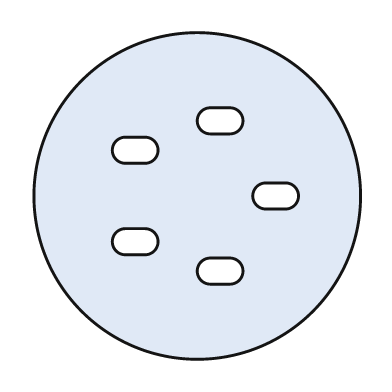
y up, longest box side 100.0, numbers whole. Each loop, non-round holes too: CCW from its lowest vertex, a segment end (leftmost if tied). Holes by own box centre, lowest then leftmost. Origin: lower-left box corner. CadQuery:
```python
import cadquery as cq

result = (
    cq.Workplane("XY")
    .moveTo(50.0, 50.0)
    .circle(50.0)
    .moveTo(54.0, 23.0)
    .lineTo(60.0, 23.0)
    .threePointArc((64.0, 27.0), (60.0, 31.0))
    .lineTo(54.0, 31.0)
    .threePointArc((50.0, 27.0), (54.0, 23.0))
    .close()
    .moveTo(28.0, 32.0)
    .lineTo(34.0, 32.0)
    .threePointArc((38.0, 36.0), (34.0, 40.0))
    .lineTo(28.0, 40.0)
    .threePointArc((24.0, 36.0), (28.0, 32.0))
    .close()
    .moveTo(71.0, 46.0)
    .lineTo(77.0, 46.0)
    .threePointArc((81.0, 50.0), (77.0, 54.0))
    .lineTo(71.0, 54.0)
    .threePointArc((67.0, 50.0), (71.0, 46.0))
    .close()
    .moveTo(28.0, 60.0)
    .lineTo(34.0, 60.0)
    .threePointArc((38.0, 64.0), (34.0, 68.0))
    .lineTo(28.0, 68.0)
    .threePointArc((24.0, 64.0), (28.0, 60.0))
    .close()
    .moveTo(54.0, 69.0)
    .lineTo(60.0, 69.0)
    .threePointArc((64.0, 73.0), (60.0, 77.0))
    .lineTo(54.0, 77.0)
    .threePointArc((50.0, 73.0), (54.0, 69.0))
    .close()
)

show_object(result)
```